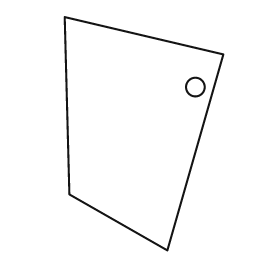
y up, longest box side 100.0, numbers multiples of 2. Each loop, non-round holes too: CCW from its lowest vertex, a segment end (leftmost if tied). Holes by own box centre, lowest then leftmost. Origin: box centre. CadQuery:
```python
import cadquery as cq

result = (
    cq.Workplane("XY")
    .moveTo(10.0, -50.0)
    .lineTo(34.0, 34.0)
    .lineTo(-34.0, 50.0)
    .lineTo(-32.0, -26.0)
    .close()
    .moveTo(22.0, 20.0)
    .circle(4.0)
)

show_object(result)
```